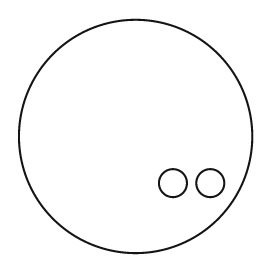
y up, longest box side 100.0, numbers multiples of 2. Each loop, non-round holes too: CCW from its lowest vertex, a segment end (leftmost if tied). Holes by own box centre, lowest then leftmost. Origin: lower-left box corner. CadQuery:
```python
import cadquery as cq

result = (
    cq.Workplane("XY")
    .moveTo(50.0, 50.0)
    .circle(50.0)
    .moveTo(66.0, 30.0)
    .circle(6.0)
    .moveTo(82.0, 30.0)
    .circle(6.0)
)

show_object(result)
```